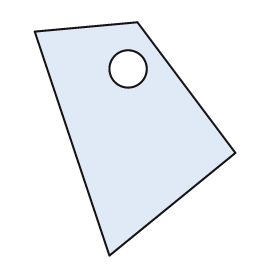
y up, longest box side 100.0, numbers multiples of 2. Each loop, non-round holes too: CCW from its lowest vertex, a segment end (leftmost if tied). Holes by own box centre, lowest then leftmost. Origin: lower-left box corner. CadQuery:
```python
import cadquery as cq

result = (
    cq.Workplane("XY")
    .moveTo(32.0, 0.0)
    .lineTo(86.0, 44.0)
    .lineTo(44.0, 100.0)
    .lineTo(0.0, 96.0)
    .close()
    .moveTo(40.0, 80.0)
    .circle(8.0)
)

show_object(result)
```